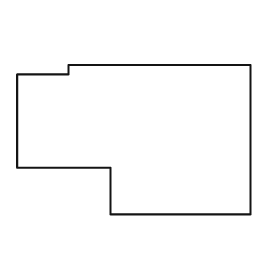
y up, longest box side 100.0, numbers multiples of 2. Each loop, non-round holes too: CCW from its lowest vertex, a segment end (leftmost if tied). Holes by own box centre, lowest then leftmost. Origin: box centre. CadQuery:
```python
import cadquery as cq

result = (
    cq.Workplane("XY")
    .moveTo(-10.0, -32.0)
    .lineTo(50.0, -32.0)
    .lineTo(50.0, 32.0)
    .lineTo(-28.0, 32.0)
    .lineTo(-28.0, 28.0)
    .lineTo(-50.0, 28.0)
    .lineTo(-50.0, -12.0)
    .lineTo(-10.0, -12.0)
    .close()
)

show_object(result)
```